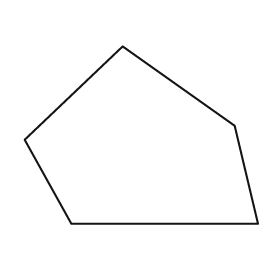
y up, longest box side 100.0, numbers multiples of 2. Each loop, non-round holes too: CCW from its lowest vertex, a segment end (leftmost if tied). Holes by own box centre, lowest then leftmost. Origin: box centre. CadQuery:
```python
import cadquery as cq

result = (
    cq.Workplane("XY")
    .moveTo(-30.0, -38.0)
    .lineTo(50.0, -38.0)
    .lineTo(40.0, 4.0)
    .lineTo(-8.0, 38.0)
    .lineTo(-50.0, -2.0)
    .close()
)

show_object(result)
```